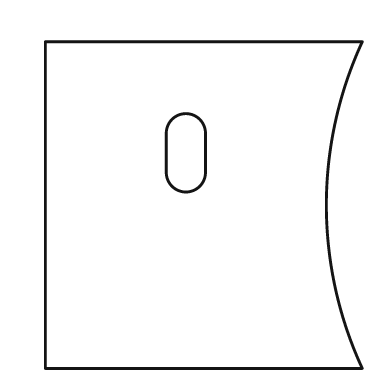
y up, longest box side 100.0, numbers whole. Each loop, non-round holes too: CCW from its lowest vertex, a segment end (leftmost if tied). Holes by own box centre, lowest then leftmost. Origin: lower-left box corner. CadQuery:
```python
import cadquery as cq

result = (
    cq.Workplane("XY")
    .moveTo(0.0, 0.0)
    .lineTo(97.0, 0.0)
    .threePointArc((86.0, 50.0), (97.0, 100.0))
    .lineTo(0.0, 100.0)
    .close()
    .moveTo(37.0, 60.0)
    .threePointArc((43.0, 54.0), (49.0, 60.0))
    .lineTo(49.0, 72.0)
    .threePointArc((43.0, 78.0), (37.0, 72.0))
    .close()
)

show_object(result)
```